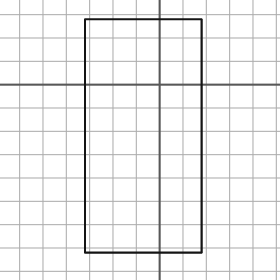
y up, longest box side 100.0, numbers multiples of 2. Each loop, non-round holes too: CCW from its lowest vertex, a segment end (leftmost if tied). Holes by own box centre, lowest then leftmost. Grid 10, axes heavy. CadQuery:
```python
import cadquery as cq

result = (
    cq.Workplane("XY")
    .moveTo(-32.0, -72.0)
    .lineTo(18.0, -72.0)
    .lineTo(18.0, 28.0)
    .lineTo(-32.0, 28.0)
    .close()
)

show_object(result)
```